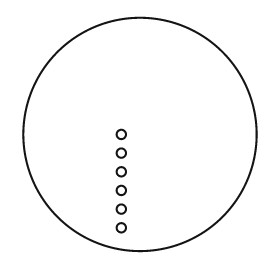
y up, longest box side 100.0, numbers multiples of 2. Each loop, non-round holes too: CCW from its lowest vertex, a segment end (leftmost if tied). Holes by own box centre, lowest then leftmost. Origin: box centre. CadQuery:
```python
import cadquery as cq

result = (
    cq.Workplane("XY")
    .moveTo(0.0, 0.0)
    .circle(50.0)
    .moveTo(-8.0, -40.0)
    .circle(2.0)
    .moveTo(-8.0, -32.0)
    .circle(2.0)
    .moveTo(-8.0, -24.0)
    .circle(2.0)
    .moveTo(-8.0, -16.0)
    .circle(2.0)
    .moveTo(-8.0, -8.0)
    .circle(2.0)
    .moveTo(-8.0, 0.0)
    .circle(2.0)
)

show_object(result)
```